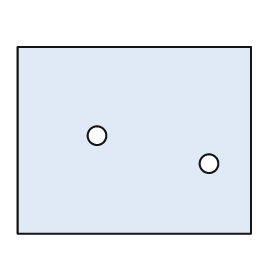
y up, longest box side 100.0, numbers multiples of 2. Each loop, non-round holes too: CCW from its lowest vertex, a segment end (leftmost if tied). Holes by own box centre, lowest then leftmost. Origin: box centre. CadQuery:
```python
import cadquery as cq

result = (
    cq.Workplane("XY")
    .moveTo(-50.0, -40.0)
    .lineTo(50.0, -40.0)
    .lineTo(50.0, 40.0)
    .lineTo(-50.0, 40.0)
    .close()
    .moveTo(32.0, -10.0)
    .circle(4.0)
    .moveTo(-16.0, 2.0)
    .circle(4.0)
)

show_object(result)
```